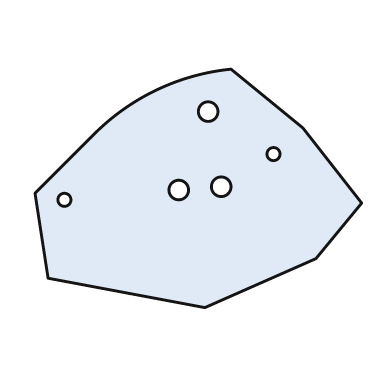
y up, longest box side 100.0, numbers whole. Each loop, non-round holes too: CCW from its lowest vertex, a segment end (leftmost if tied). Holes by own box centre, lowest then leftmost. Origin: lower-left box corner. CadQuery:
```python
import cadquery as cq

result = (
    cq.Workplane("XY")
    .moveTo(52.0, 0.0)
    .lineTo(86.0, 15.0)
    .lineTo(100.0, 32.0)
    .lineTo(82.0, 55.0)
    .lineTo(60.0, 73.0)
    .threePointArc((38.0, 67.0), (19.0, 54.0))
    .lineTo(0.0, 35.0)
    .lineTo(4.0, 9.0)
    .close()
    .moveTo(9.0, 33.0)
    .circle(2.0)
    .moveTo(44.0, 36.0)
    .circle(3.0)
    .moveTo(57.0, 37.0)
    .circle(3.0)
    .moveTo(73.0, 47.0)
    .circle(2.0)
    .moveTo(53.0, 60.0)
    .circle(3.0)
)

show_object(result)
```